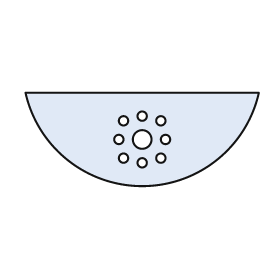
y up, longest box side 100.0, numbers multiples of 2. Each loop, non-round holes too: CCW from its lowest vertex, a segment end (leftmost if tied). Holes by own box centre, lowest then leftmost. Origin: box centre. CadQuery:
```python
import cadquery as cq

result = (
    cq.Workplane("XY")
    .moveTo(-50.0, 20.0)
    .threePointArc((0.0, -20.0), (50.0, 20.0))
    .close()
    .moveTo(0.0, -10.0)
    .circle(2.0)
    .moveTo(-8.0, -8.0)
    .circle(2.0)
    .moveTo(8.0, -8.0)
    .circle(2.0)
    .moveTo(-10.0, 0.0)
    .circle(2.0)
    .moveTo(0.0, 0.0)
    .circle(4.0)
    .moveTo(10.0, 0.0)
    .circle(2.0)
    .moveTo(-8.0, 8.0)
    .circle(2.0)
    .moveTo(8.0, 8.0)
    .circle(2.0)
    .moveTo(0.0, 10.0)
    .circle(2.0)
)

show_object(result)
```